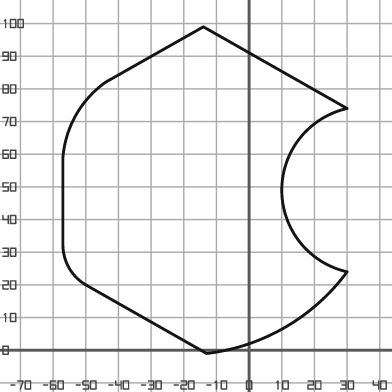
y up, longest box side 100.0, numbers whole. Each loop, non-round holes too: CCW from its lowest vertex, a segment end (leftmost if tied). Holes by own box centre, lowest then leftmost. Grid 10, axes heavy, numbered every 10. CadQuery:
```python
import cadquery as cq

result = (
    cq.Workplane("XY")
    .moveTo(-13.0, -1.0)
    .threePointArc((11.0, 7.0), (30.0, 24.0))
    .threePointArc((10.0, 49.0), (30.0, 74.0))
    .lineTo(-14.0, 99.0)
    .lineTo(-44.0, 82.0)
    .threePointArc((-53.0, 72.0), (-57.0, 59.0))
    .lineTo(-57.0, 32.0)
    .threePointArc((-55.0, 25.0), (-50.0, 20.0))
    .close()
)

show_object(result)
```